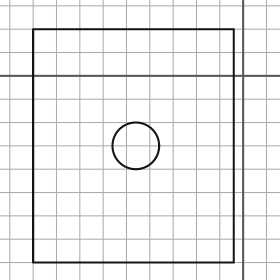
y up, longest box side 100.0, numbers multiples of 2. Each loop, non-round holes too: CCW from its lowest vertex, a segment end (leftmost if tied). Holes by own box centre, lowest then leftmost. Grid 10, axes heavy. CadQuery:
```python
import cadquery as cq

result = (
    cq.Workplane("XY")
    .moveTo(-90.0, -80.0)
    .lineTo(-4.0, -80.0)
    .lineTo(-4.0, 20.0)
    .lineTo(-90.0, 20.0)
    .close()
    .moveTo(-46.0, -30.0)
    .circle(10.0)
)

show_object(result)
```